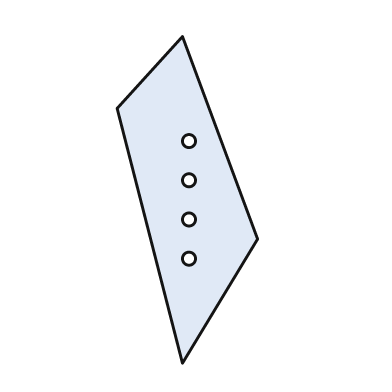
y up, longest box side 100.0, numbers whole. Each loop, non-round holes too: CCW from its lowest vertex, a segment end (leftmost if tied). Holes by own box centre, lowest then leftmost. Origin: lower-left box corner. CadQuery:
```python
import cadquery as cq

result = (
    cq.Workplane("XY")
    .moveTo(20.0, 0.0)
    .lineTo(43.0, 38.0)
    .lineTo(20.0, 100.0)
    .lineTo(0.0, 78.0)
    .close()
    .moveTo(22.0, 32.0)
    .circle(2.0)
    .moveTo(22.0, 44.0)
    .circle(2.0)
    .moveTo(22.0, 56.0)
    .circle(2.0)
    .moveTo(22.0, 68.0)
    .circle(2.0)
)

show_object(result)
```